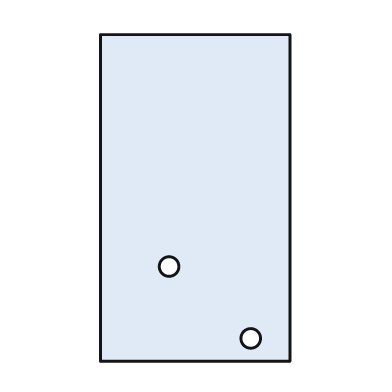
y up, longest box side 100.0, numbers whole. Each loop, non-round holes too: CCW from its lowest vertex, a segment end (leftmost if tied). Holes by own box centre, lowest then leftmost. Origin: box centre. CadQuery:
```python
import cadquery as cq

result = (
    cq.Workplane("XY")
    .moveTo(-29.0, -50.0)
    .lineTo(29.0, -50.0)
    .lineTo(29.0, 50.0)
    .lineTo(-29.0, 50.0)
    .close()
    .moveTo(17.0, -43.0)
    .circle(3.0)
    .moveTo(-8.0, -21.0)
    .circle(3.0)
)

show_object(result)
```